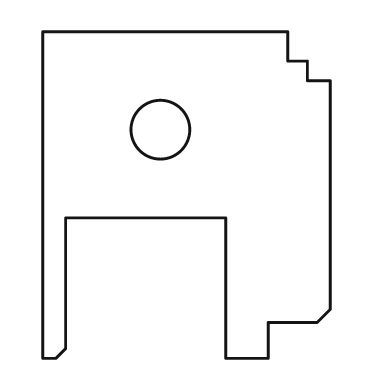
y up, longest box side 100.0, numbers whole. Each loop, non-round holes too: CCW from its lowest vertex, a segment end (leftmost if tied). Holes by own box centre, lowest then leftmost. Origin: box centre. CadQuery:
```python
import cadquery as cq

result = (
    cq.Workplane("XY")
    .moveTo(-44.0, -50.0)
    .lineTo(-40.0, -50.0)
    .lineTo(-37.0, -47.0)
    .lineTo(-37.0, -7.0)
    .lineTo(12.0, -7.0)
    .lineTo(12.0, -50.0)
    .lineTo(25.0, -50.0)
    .lineTo(25.0, -39.0)
    .lineTo(40.0, -39.0)
    .lineTo(44.0, -35.0)
    .lineTo(44.0, 35.0)
    .lineTo(37.0, 35.0)
    .lineTo(37.0, 41.0)
    .lineTo(31.0, 41.0)
    .lineTo(31.0, 50.0)
    .lineTo(-44.0, 50.0)
    .close()
    .moveTo(-8.0, 20.0)
    .circle(9.0)
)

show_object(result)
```